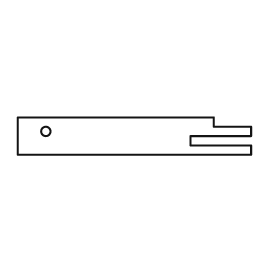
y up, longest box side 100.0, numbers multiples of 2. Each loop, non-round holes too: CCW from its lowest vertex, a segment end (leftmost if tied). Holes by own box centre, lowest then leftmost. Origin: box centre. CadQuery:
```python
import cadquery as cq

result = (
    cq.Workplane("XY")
    .moveTo(-50.0, -8.0)
    .lineTo(50.0, -8.0)
    .lineTo(50.0, -4.0)
    .lineTo(24.0, -4.0)
    .lineTo(24.0, 0.0)
    .lineTo(50.0, 0.0)
    .lineTo(50.0, 4.0)
    .lineTo(34.0, 4.0)
    .lineTo(34.0, 8.0)
    .lineTo(-50.0, 8.0)
    .close()
    .moveTo(-38.0, 2.0)
    .circle(2.0)
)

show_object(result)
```